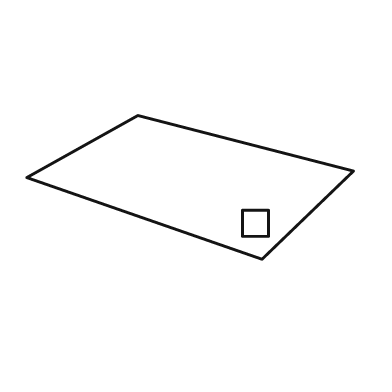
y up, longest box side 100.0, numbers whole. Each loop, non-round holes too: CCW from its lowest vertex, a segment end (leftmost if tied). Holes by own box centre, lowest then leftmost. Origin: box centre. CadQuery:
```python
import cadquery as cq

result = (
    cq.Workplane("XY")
    .moveTo(22.0, -22.0)
    .lineTo(50.0, 5.0)
    .lineTo(-16.0, 22.0)
    .lineTo(-50.0, 3.0)
    .close()
    .moveTo(16.0, -15.0)
    .lineTo(24.0, -15.0)
    .lineTo(24.0, -7.0)
    .lineTo(16.0, -7.0)
    .close()
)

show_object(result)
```